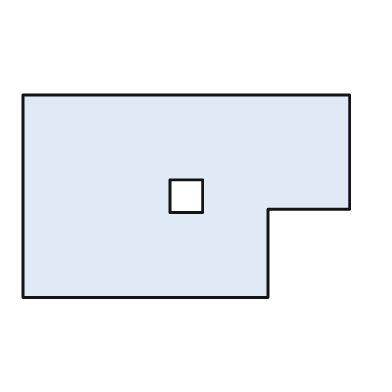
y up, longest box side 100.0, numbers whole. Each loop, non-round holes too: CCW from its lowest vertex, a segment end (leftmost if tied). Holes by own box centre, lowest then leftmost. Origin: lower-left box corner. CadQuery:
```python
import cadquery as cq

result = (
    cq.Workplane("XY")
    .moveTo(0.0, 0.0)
    .lineTo(75.0, 0.0)
    .lineTo(75.0, 27.0)
    .lineTo(100.0, 27.0)
    .lineTo(100.0, 62.0)
    .lineTo(0.0, 62.0)
    .close()
    .moveTo(45.0, 26.0)
    .lineTo(55.0, 26.0)
    .lineTo(55.0, 36.0)
    .lineTo(45.0, 36.0)
    .close()
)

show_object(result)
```